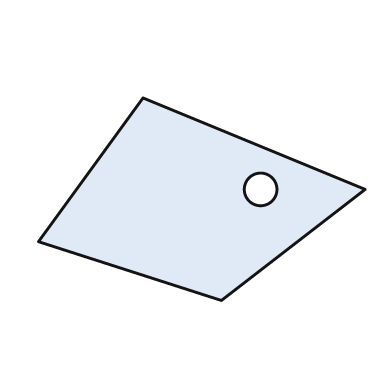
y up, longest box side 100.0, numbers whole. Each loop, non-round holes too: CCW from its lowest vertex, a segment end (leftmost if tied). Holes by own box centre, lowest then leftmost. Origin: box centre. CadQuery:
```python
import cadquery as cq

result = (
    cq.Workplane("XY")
    .moveTo(6.0, -31.0)
    .lineTo(50.0, 3.0)
    .lineTo(-18.0, 31.0)
    .lineTo(-50.0, -13.0)
    .close()
    .moveTo(18.0, 3.0)
    .circle(5.0)
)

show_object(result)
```